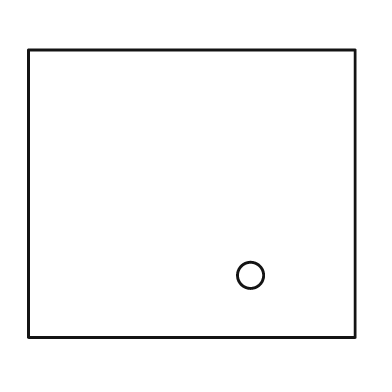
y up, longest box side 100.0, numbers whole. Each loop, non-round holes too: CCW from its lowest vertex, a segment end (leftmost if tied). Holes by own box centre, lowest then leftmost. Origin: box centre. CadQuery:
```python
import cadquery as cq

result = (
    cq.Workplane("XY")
    .moveTo(-50.0, -44.0)
    .lineTo(50.0, -44.0)
    .lineTo(50.0, 44.0)
    .lineTo(-50.0, 44.0)
    .close()
    .moveTo(18.0, -25.0)
    .circle(4.0)
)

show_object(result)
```